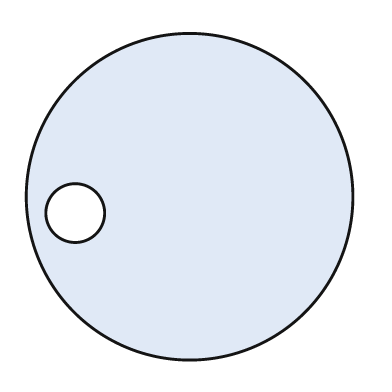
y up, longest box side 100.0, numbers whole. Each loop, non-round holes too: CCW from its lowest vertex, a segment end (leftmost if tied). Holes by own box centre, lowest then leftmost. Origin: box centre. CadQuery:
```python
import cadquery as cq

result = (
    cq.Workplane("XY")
    .moveTo(0.0, 0.0)
    .circle(50.0)
    .moveTo(-35.0, -5.0)
    .circle(9.0)
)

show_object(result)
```